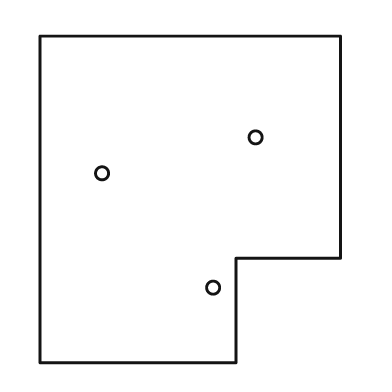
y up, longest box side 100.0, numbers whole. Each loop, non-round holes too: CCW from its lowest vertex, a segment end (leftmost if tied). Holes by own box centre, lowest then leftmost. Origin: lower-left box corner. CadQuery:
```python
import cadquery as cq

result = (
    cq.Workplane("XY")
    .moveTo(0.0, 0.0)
    .lineTo(60.0, 0.0)
    .lineTo(60.0, 32.0)
    .lineTo(92.0, 32.0)
    .lineTo(92.0, 100.0)
    .lineTo(0.0, 100.0)
    .close()
    .moveTo(53.0, 23.0)
    .circle(2.0)
    .moveTo(19.0, 58.0)
    .circle(2.0)
    .moveTo(66.0, 69.0)
    .circle(2.0)
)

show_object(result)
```